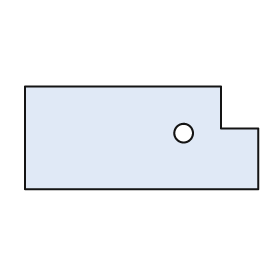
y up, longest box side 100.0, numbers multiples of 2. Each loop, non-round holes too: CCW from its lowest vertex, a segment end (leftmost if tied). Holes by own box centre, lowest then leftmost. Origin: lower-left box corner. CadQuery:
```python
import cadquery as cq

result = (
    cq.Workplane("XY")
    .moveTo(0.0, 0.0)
    .lineTo(100.0, 0.0)
    .lineTo(100.0, 26.0)
    .lineTo(84.0, 26.0)
    .lineTo(84.0, 44.0)
    .lineTo(0.0, 44.0)
    .close()
    .moveTo(68.0, 24.0)
    .circle(4.0)
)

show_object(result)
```